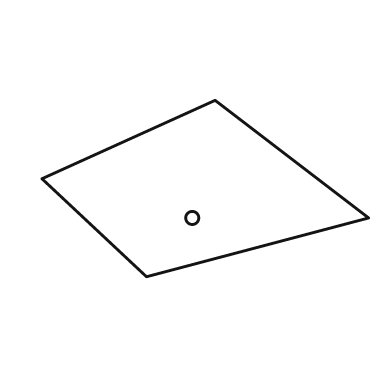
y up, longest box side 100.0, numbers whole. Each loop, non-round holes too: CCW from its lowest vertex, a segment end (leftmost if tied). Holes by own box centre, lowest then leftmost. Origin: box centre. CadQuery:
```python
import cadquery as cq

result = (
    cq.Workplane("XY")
    .moveTo(-18.0, -27.0)
    .lineTo(50.0, -9.0)
    .lineTo(3.0, 27.0)
    .lineTo(-50.0, 3.0)
    .close()
    .moveTo(-4.0, -9.0)
    .circle(2.0)
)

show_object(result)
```